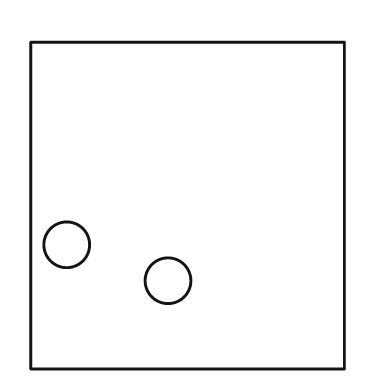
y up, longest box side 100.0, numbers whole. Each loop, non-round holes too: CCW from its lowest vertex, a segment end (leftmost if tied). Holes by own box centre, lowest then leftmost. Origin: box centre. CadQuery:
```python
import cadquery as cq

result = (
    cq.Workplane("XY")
    .moveTo(-48.0, -50.0)
    .lineTo(48.0, -50.0)
    .lineTo(48.0, 50.0)
    .lineTo(-48.0, 50.0)
    .close()
    .moveTo(-6.0, -23.0)
    .circle(7.0)
    .moveTo(-37.0, -12.0)
    .circle(7.0)
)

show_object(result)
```